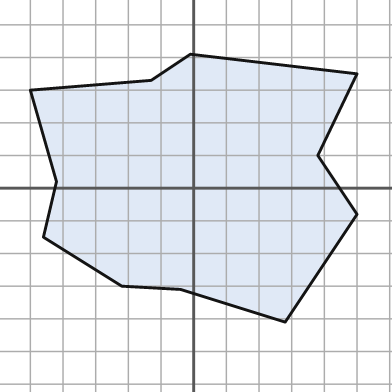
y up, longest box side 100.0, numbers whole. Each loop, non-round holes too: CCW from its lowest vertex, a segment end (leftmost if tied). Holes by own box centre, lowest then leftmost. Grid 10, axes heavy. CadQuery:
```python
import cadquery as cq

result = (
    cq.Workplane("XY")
    .moveTo(28.0, -41.0)
    .lineTo(50.0, -8.0)
    .lineTo(38.0, 10.0)
    .lineTo(50.0, 35.0)
    .lineTo(-1.0, 41.0)
    .lineTo(-13.0, 33.0)
    .lineTo(-50.0, 30.0)
    .lineTo(-42.0, 2.0)
    .lineTo(-46.0, -15.0)
    .lineTo(-22.0, -30.0)
    .lineTo(-4.0, -31.0)
    .close()
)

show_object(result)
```